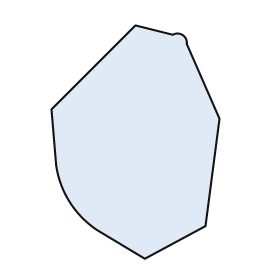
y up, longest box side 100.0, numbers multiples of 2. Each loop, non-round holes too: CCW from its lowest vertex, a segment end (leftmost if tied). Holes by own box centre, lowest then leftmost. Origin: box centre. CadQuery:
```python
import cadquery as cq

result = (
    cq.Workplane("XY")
    .moveTo(4.0, -50.0)
    .lineTo(30.0, -36.0)
    .lineTo(36.0, 10.0)
    .lineTo(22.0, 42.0)
    .threePointArc((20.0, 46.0), (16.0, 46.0))
    .lineTo(0.0, 50.0)
    .lineTo(-36.0, 14.0)
    .lineTo(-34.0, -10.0)
    .threePointArc((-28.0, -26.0), (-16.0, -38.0))
    .close()
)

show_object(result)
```